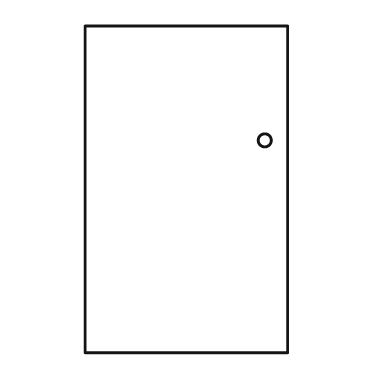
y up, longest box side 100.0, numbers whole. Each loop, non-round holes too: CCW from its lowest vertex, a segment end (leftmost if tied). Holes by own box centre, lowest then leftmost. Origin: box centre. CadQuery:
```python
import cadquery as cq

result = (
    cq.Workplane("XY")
    .moveTo(-31.0, -50.0)
    .lineTo(31.0, -50.0)
    .lineTo(31.0, 50.0)
    .lineTo(-31.0, 50.0)
    .close()
    .moveTo(24.0, 15.0)
    .circle(2.0)
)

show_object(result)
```